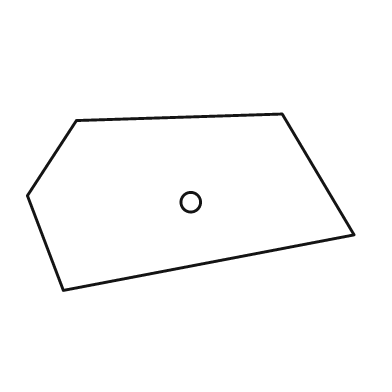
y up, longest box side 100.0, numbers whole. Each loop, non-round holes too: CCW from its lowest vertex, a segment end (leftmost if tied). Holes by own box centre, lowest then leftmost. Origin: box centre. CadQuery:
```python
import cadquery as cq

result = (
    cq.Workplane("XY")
    .moveTo(-39.0, -27.0)
    .lineTo(50.0, -10.0)
    .lineTo(28.0, 27.0)
    .lineTo(-35.0, 25.0)
    .lineTo(-50.0, 2.0)
    .close()
    .moveTo(0.0, 0.0)
    .circle(3.0)
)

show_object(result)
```